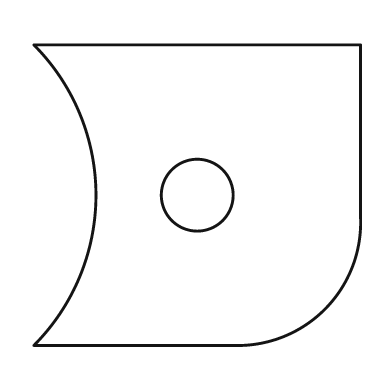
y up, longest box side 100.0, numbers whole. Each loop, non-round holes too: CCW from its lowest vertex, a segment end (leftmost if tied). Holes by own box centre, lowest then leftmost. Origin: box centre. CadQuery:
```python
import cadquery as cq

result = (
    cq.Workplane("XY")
    .moveTo(-50.0, -46.0)
    .lineTo(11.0, -46.0)
    .threePointArc((39.0, -35.0), (50.0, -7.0))
    .lineTo(50.0, 46.0)
    .lineTo(-50.0, 46.0)
    .threePointArc((-31.0, 0.0), (-50.0, -46.0))
    .close()
    .moveTo(0.0, 0.0)
    .circle(11.0)
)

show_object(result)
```